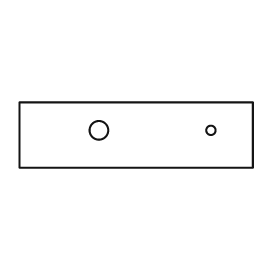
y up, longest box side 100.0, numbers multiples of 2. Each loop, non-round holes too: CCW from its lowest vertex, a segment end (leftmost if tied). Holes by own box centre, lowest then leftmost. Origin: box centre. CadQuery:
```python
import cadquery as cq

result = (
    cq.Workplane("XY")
    .moveTo(-50.0, -14.0)
    .lineTo(50.0, -14.0)
    .lineTo(50.0, 14.0)
    .lineTo(-50.0, 14.0)
    .close()
    .moveTo(-16.0, 2.0)
    .circle(4.0)
    .moveTo(32.0, 2.0)
    .circle(2.0)
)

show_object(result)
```